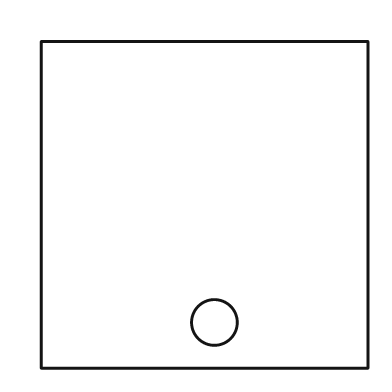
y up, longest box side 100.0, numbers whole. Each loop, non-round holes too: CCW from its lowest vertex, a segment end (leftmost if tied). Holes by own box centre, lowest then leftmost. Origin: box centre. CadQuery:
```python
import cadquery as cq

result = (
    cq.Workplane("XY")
    .moveTo(-50.0, -50.0)
    .lineTo(50.0, -50.0)
    .lineTo(50.0, 50.0)
    .lineTo(-50.0, 50.0)
    .close()
    .moveTo(3.0, -36.0)
    .circle(7.0)
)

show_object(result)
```